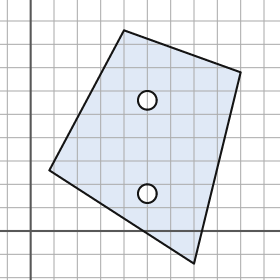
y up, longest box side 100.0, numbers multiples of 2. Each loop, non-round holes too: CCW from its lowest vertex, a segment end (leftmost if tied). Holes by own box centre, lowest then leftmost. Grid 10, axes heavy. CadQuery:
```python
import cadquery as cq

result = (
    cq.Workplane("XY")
    .moveTo(70.0, -14.0)
    .lineTo(90.0, 68.0)
    .lineTo(40.0, 86.0)
    .lineTo(8.0, 26.0)
    .close()
    .moveTo(50.0, 16.0)
    .circle(4.0)
    .moveTo(50.0, 56.0)
    .circle(4.0)
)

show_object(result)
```